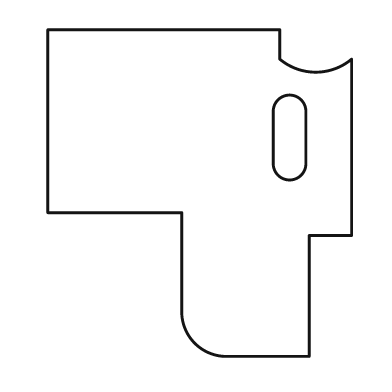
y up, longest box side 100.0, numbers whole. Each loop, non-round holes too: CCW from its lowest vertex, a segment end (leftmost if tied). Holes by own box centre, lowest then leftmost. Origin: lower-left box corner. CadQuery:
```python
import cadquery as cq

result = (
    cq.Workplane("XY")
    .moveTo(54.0, 0.0)
    .lineTo(80.0, 0.0)
    .lineTo(80.0, 37.0)
    .lineTo(93.0, 37.0)
    .lineTo(93.0, 91.0)
    .threePointArc((82.0, 87.0), (71.0, 91.0))
    .lineTo(71.0, 100.0)
    .lineTo(0.0, 100.0)
    .lineTo(0.0, 44.0)
    .lineTo(41.0, 44.0)
    .lineTo(41.0, 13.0)
    .threePointArc((45.0, 4.0), (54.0, 0.0))
    .close()
    .moveTo(69.0, 59.0)
    .threePointArc((74.0, 54.0), (79.0, 59.0))
    .lineTo(79.0, 75.0)
    .threePointArc((74.0, 80.0), (69.0, 75.0))
    .close()
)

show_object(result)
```